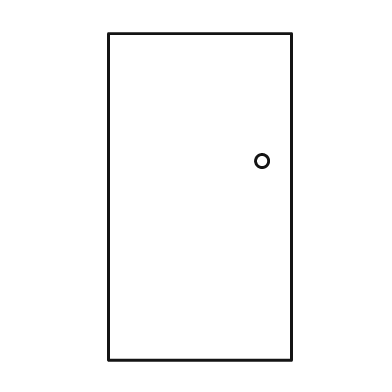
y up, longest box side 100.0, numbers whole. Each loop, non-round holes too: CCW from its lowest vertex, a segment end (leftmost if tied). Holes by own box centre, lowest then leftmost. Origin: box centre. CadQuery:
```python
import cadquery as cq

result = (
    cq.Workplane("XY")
    .moveTo(-28.0, -50.0)
    .lineTo(28.0, -50.0)
    .lineTo(28.0, 50.0)
    .lineTo(-28.0, 50.0)
    .close()
    .moveTo(19.0, 11.0)
    .circle(2.0)
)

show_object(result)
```